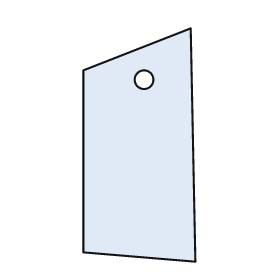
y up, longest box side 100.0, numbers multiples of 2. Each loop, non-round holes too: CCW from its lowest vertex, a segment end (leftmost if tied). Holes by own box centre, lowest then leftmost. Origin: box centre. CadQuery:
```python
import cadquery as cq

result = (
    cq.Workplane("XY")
    .moveTo(24.0, -50.0)
    .lineTo(22.0, 50.0)
    .lineTo(-24.0, 32.0)
    .lineTo(-24.0, -46.0)
    .close()
    .moveTo(2.0, 28.0)
    .circle(4.0)
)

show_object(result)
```